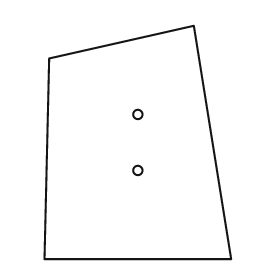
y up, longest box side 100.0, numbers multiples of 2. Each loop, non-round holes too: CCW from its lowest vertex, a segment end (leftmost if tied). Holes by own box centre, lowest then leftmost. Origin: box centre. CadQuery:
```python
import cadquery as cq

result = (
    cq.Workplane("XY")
    .moveTo(-40.0, -50.0)
    .lineTo(40.0, -50.0)
    .lineTo(24.0, 50.0)
    .lineTo(-38.0, 36.0)
    .close()
    .moveTo(0.0, -12.0)
    .circle(2.0)
    .moveTo(0.0, 12.0)
    .circle(2.0)
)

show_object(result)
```